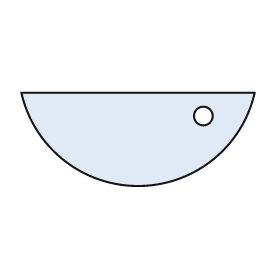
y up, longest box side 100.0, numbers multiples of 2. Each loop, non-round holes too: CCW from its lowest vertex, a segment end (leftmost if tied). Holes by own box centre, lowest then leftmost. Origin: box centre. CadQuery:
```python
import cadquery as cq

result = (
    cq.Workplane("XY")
    .moveTo(-50.0, 20.0)
    .threePointArc((0.0, -20.0), (50.0, 20.0))
    .close()
    .moveTo(28.0, 10.0)
    .circle(4.0)
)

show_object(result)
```